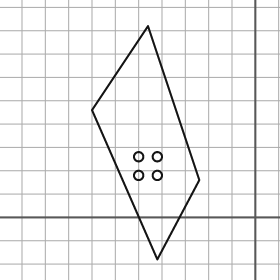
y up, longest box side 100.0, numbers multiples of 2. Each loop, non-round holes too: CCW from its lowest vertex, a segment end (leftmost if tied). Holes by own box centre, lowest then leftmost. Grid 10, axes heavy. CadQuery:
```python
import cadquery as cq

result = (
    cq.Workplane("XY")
    .moveTo(-42.0, -18.0)
    .lineTo(-24.0, 16.0)
    .lineTo(-46.0, 82.0)
    .lineTo(-70.0, 46.0)
    .close()
    .moveTo(-50.0, 18.0)
    .circle(2.0)
    .moveTo(-42.0, 18.0)
    .circle(2.0)
    .moveTo(-50.0, 26.0)
    .circle(2.0)
    .moveTo(-42.0, 26.0)
    .circle(2.0)
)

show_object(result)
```